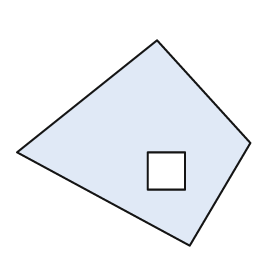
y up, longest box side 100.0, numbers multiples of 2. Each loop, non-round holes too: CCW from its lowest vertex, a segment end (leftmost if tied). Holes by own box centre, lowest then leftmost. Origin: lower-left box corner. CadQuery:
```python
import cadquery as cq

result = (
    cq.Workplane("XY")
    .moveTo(74.0, 0.0)
    .lineTo(100.0, 44.0)
    .lineTo(60.0, 88.0)
    .lineTo(0.0, 40.0)
    .close()
    .moveTo(56.0, 24.0)
    .lineTo(72.0, 24.0)
    .lineTo(72.0, 40.0)
    .lineTo(56.0, 40.0)
    .close()
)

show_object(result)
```